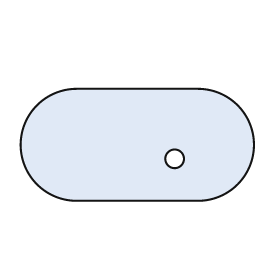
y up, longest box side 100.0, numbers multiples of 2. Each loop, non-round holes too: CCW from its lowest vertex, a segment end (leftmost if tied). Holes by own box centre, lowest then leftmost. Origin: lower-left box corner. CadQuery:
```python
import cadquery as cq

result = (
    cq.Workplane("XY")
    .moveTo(24.0, 0.0)
    .lineTo(76.0, 0.0)
    .threePointArc((100.0, 24.0), (76.0, 48.0))
    .lineTo(24.0, 48.0)
    .threePointArc((0.0, 24.0), (24.0, 0.0))
    .close()
    .moveTo(66.0, 18.0)
    .circle(4.0)
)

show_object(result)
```